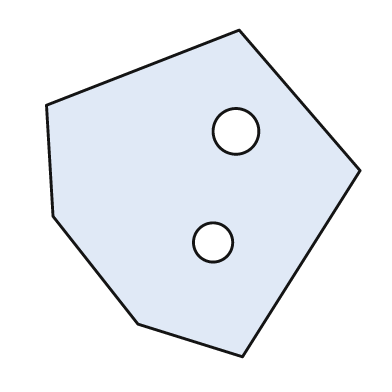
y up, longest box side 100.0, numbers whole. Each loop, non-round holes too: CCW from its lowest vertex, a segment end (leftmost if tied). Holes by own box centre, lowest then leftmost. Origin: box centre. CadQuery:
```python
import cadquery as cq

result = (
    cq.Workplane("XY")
    .moveTo(12.0, -50.0)
    .lineTo(48.0, 7.0)
    .lineTo(11.0, 50.0)
    .lineTo(-48.0, 27.0)
    .lineTo(-46.0, -7.0)
    .lineTo(-20.0, -40.0)
    .close()
    .moveTo(3.0, -15.0)
    .circle(6.0)
    .moveTo(10.0, 19.0)
    .circle(7.0)
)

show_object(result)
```